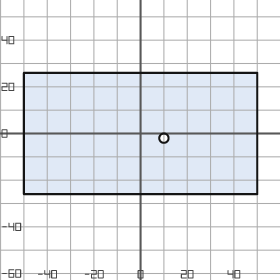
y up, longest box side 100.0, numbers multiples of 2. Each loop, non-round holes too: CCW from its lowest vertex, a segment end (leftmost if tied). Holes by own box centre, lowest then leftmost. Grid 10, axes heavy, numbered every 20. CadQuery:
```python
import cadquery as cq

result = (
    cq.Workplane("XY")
    .moveTo(-50.0, -26.0)
    .lineTo(50.0, -26.0)
    .lineTo(50.0, 26.0)
    .lineTo(-50.0, 26.0)
    .close()
    .moveTo(10.0, -2.0)
    .circle(2.0)
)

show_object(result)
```